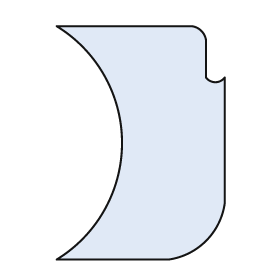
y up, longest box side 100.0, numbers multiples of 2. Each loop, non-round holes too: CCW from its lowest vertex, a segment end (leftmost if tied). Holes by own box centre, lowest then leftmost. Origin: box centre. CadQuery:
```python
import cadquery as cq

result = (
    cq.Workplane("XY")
    .moveTo(-36.0, -50.0)
    .lineTo(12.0, -50.0)
    .threePointArc((28.0, -42.0), (36.0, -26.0))
    .lineTo(36.0, 28.0)
    .threePointArc((32.0, 26.0), (28.0, 28.0))
    .lineTo(28.0, 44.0)
    .threePointArc((26.0, 48.0), (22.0, 50.0))
    .lineTo(-36.0, 50.0)
    .threePointArc((-8.0, 0.0), (-36.0, -50.0))
    .close()
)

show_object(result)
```